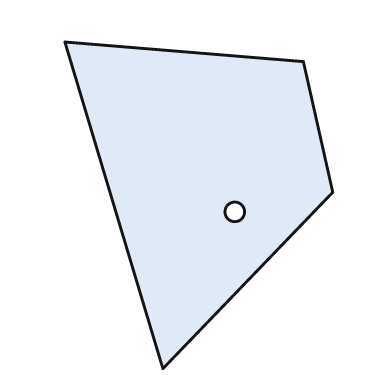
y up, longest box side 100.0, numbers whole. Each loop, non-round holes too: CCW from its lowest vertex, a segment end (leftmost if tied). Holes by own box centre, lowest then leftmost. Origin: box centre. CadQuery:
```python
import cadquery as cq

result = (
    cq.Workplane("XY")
    .moveTo(-11.0, -50.0)
    .lineTo(41.0, 4.0)
    .lineTo(32.0, 44.0)
    .lineTo(-41.0, 50.0)
    .close()
    .moveTo(11.0, -2.0)
    .circle(3.0)
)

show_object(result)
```